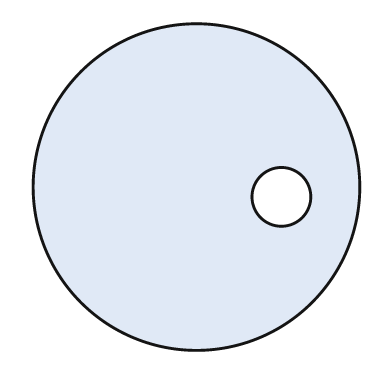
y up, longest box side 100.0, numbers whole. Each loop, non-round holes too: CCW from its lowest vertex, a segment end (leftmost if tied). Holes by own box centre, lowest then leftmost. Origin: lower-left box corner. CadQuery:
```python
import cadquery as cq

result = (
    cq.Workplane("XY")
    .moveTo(50.0, 50.0)
    .circle(50.0)
    .moveTo(76.0, 47.0)
    .circle(9.0)
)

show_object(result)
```